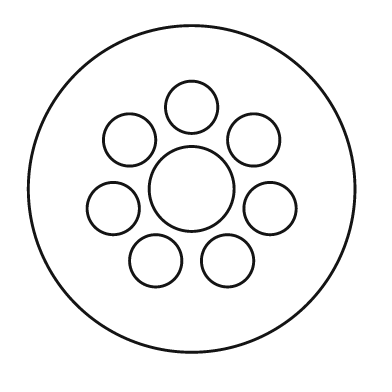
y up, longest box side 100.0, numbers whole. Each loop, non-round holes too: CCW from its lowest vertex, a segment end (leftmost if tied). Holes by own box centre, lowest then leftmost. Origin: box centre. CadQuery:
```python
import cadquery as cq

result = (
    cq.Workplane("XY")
    .moveTo(0.0, 0.0)
    .circle(50.0)
    .moveTo(-11.0, -22.0)
    .circle(8.0)
    .moveTo(11.0, -22.0)
    .circle(8.0)
    .moveTo(-24.0, -6.0)
    .circle(8.0)
    .moveTo(24.0, -6.0)
    .circle(8.0)
    .moveTo(0.0, 0.0)
    .circle(13.0)
    .moveTo(-19.0, 15.0)
    .circle(8.0)
    .moveTo(19.0, 15.0)
    .circle(8.0)
    .moveTo(0.0, 25.0)
    .circle(8.0)
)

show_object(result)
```